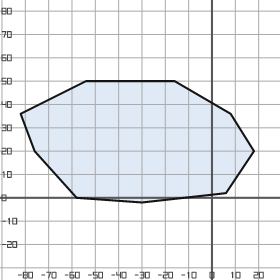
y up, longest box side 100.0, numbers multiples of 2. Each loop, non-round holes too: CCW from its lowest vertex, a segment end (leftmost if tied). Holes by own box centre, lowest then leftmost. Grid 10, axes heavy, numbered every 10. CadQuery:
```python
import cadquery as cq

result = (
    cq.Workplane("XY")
    .moveTo(-30.0, -2.0)
    .lineTo(6.0, 2.0)
    .lineTo(18.0, 20.0)
    .lineTo(8.0, 36.0)
    .lineTo(-16.0, 50.0)
    .lineTo(-54.0, 50.0)
    .lineTo(-82.0, 36.0)
    .lineTo(-76.0, 20.0)
    .lineTo(-58.0, 0.0)
    .close()
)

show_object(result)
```